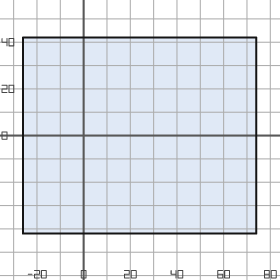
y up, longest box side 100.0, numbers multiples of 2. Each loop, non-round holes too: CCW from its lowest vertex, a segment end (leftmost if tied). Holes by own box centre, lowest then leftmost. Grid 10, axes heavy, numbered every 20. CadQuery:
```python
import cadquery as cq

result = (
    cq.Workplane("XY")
    .moveTo(-26.0, -42.0)
    .lineTo(74.0, -42.0)
    .lineTo(74.0, 42.0)
    .lineTo(-26.0, 42.0)
    .close()
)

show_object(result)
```